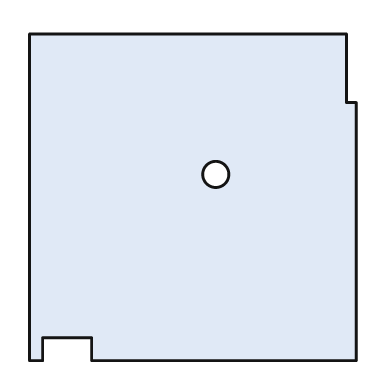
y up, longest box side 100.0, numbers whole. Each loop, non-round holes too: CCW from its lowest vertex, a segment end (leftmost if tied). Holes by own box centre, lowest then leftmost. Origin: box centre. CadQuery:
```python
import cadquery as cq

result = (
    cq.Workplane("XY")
    .moveTo(-50.0, -50.0)
    .lineTo(-46.0, -50.0)
    .lineTo(-46.0, -43.0)
    .lineTo(-31.0, -43.0)
    .lineTo(-31.0, -50.0)
    .lineTo(50.0, -50.0)
    .lineTo(50.0, 29.0)
    .lineTo(47.0, 29.0)
    .lineTo(47.0, 50.0)
    .lineTo(-50.0, 50.0)
    .close()
    .moveTo(7.0, 7.0)
    .circle(4.0)
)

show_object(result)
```